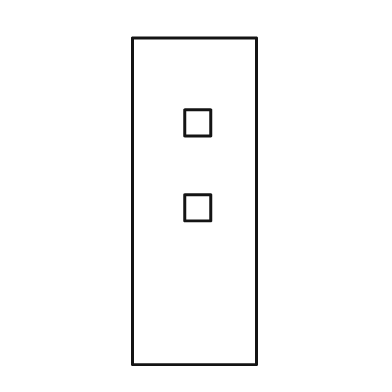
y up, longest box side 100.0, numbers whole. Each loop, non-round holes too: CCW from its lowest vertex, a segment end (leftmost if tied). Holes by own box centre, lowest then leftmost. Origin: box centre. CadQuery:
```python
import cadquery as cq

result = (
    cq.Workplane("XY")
    .moveTo(-19.0, -50.0)
    .lineTo(19.0, -50.0)
    .lineTo(19.0, 50.0)
    .lineTo(-19.0, 50.0)
    .close()
    .moveTo(-3.0, -6.0)
    .lineTo(5.0, -6.0)
    .lineTo(5.0, 2.0)
    .lineTo(-3.0, 2.0)
    .close()
    .moveTo(-3.0, 20.0)
    .lineTo(5.0, 20.0)
    .lineTo(5.0, 28.0)
    .lineTo(-3.0, 28.0)
    .close()
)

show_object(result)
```